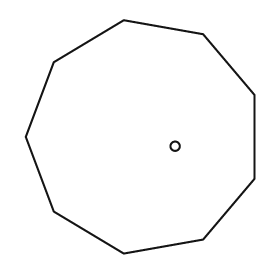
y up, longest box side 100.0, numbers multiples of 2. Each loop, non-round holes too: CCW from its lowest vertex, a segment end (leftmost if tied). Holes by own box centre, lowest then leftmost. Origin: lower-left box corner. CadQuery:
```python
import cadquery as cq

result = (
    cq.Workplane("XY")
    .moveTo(42.0, 0.0)
    .lineTo(76.0, 6.0)
    .lineTo(98.0, 32.0)
    .lineTo(98.0, 68.0)
    .lineTo(76.0, 94.0)
    .lineTo(42.0, 100.0)
    .lineTo(12.0, 82.0)
    .lineTo(0.0, 50.0)
    .lineTo(12.0, 18.0)
    .close()
    .moveTo(64.0, 46.0)
    .circle(2.0)
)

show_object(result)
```